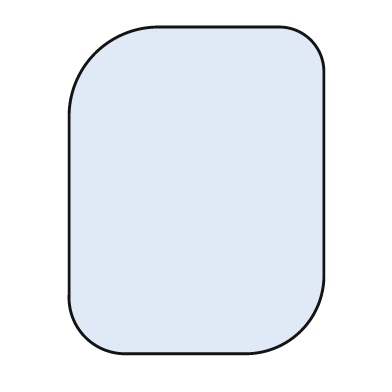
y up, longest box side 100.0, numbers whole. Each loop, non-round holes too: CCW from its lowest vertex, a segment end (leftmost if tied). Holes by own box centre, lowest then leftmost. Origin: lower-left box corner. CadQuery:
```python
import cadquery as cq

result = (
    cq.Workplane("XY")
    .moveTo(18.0, 0.0)
    .lineTo(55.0, 0.0)
    .threePointArc((71.0, 7.0), (78.0, 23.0))
    .lineTo(78.0, 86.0)
    .threePointArc((74.0, 96.0), (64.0, 100.0))
    .lineTo(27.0, 100.0)
    .threePointArc((8.0, 92.0), (0.0, 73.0))
    .lineTo(0.0, 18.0)
    .threePointArc((5.0, 5.0), (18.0, 0.0))
    .close()
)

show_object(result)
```